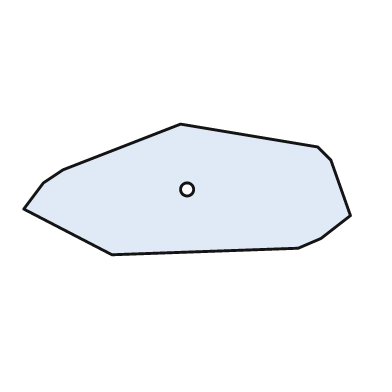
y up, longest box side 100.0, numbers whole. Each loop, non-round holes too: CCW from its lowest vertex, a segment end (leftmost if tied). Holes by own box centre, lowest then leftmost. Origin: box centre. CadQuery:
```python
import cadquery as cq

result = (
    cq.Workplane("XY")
    .moveTo(-23.0, -20.0)
    .lineTo(34.0, -18.0)
    .lineTo(41.0, -15.0)
    .lineTo(50.0, -8.0)
    .lineTo(44.0, 9.0)
    .lineTo(40.0, 13.0)
    .lineTo(-2.0, 20.0)
    .lineTo(-38.0, 6.0)
    .lineTo(-44.0, 2.0)
    .lineTo(-50.0, -6.0)
    .close()
    .moveTo(0.0, 0.0)
    .circle(2.0)
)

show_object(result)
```